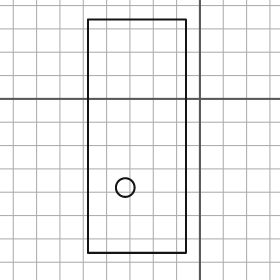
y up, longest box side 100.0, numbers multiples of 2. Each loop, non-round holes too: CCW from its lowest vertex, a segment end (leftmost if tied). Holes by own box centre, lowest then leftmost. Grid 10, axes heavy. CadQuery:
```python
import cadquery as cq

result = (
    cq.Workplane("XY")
    .moveTo(-48.0, -66.0)
    .lineTo(-6.0, -66.0)
    .lineTo(-6.0, 34.0)
    .lineTo(-48.0, 34.0)
    .close()
    .moveTo(-32.0, -38.0)
    .circle(4.0)
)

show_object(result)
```